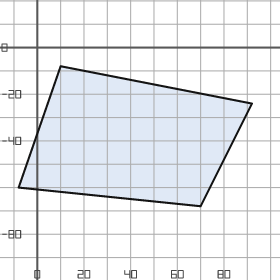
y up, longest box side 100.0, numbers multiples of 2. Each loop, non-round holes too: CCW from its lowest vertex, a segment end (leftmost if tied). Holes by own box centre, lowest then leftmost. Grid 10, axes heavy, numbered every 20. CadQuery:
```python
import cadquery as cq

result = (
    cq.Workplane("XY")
    .moveTo(70.0, -68.0)
    .lineTo(92.0, -24.0)
    .lineTo(10.0, -8.0)
    .lineTo(-8.0, -60.0)
    .close()
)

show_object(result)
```